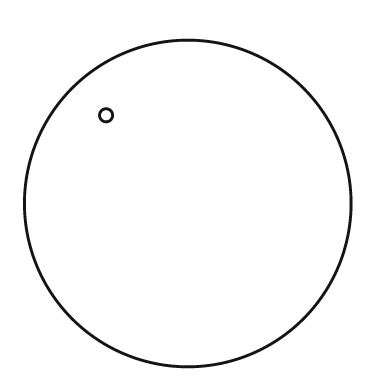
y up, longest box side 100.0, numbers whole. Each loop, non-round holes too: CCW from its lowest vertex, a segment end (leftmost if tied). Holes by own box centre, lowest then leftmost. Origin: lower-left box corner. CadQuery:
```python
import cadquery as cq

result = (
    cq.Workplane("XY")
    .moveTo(50.0, 50.0)
    .circle(50.0)
    .moveTo(25.0, 77.0)
    .circle(2.0)
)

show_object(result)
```